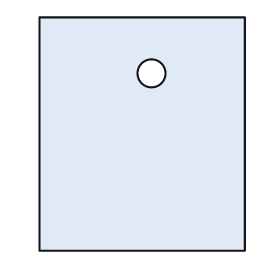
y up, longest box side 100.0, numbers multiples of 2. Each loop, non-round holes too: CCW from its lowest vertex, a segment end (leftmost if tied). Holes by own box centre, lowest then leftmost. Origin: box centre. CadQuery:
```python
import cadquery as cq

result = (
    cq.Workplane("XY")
    .moveTo(-44.0, -50.0)
    .lineTo(44.0, -50.0)
    .lineTo(44.0, 50.0)
    .lineTo(-44.0, 50.0)
    .close()
    .moveTo(4.0, 26.0)
    .circle(6.0)
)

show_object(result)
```